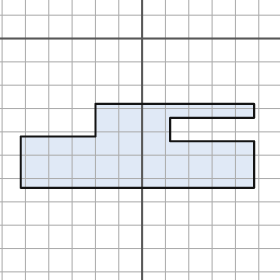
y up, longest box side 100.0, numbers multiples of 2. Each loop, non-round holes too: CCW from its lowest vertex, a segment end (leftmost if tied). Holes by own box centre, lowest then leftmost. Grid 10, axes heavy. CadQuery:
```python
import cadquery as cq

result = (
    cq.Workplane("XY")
    .moveTo(-52.0, -64.0)
    .lineTo(48.0, -64.0)
    .lineTo(48.0, -44.0)
    .lineTo(12.0, -44.0)
    .lineTo(12.0, -34.0)
    .lineTo(48.0, -34.0)
    .lineTo(48.0, -28.0)
    .lineTo(-20.0, -28.0)
    .lineTo(-20.0, -42.0)
    .lineTo(-52.0, -42.0)
    .close()
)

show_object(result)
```